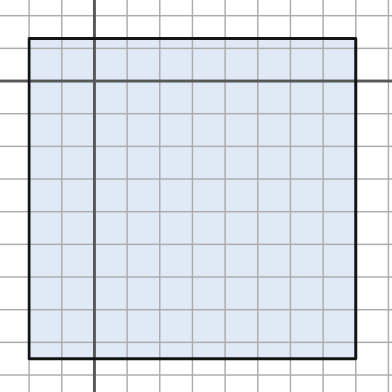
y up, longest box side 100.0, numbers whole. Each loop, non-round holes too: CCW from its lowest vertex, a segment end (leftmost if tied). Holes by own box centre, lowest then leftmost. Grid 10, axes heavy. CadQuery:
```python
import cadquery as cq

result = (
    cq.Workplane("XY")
    .moveTo(-20.0, -85.0)
    .lineTo(80.0, -85.0)
    .lineTo(80.0, 13.0)
    .lineTo(-20.0, 13.0)
    .close()
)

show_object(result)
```